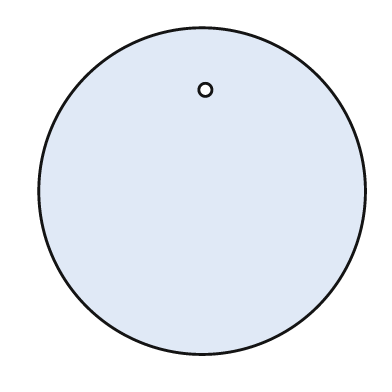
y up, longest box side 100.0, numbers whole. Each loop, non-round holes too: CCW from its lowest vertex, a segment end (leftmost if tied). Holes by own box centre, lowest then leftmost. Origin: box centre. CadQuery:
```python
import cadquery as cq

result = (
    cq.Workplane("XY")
    .moveTo(0.0, 0.0)
    .circle(50.0)
    .moveTo(1.0, 31.0)
    .circle(2.0)
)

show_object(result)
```